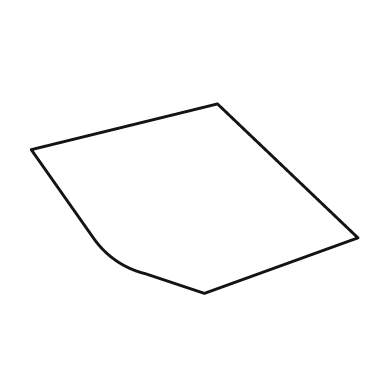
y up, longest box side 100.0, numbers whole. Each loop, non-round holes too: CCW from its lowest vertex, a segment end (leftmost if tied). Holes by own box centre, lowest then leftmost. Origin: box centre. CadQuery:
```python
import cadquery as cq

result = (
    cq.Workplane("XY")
    .moveTo(3.0, -29.0)
    .lineTo(50.0, -12.0)
    .lineTo(7.0, 29.0)
    .lineTo(-50.0, 15.0)
    .lineTo(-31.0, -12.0)
    .threePointArc((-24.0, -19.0), (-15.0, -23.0))
    .close()
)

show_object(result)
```